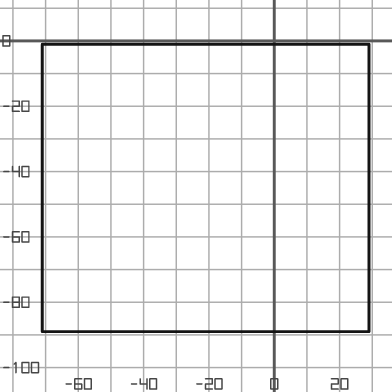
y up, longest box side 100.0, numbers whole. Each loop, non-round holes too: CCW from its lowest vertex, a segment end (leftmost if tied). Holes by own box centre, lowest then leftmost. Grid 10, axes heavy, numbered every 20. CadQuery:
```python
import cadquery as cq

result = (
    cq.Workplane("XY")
    .moveTo(-71.0, -89.0)
    .lineTo(29.0, -89.0)
    .lineTo(29.0, -1.0)
    .lineTo(-71.0, -1.0)
    .close()
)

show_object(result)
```